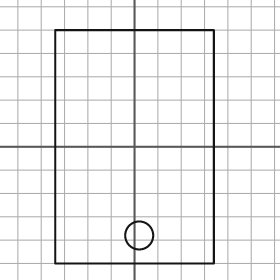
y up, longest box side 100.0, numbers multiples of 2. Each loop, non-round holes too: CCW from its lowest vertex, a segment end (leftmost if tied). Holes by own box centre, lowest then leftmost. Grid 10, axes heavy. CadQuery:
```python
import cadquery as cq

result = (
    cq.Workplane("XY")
    .moveTo(-34.0, -50.0)
    .lineTo(34.0, -50.0)
    .lineTo(34.0, 50.0)
    .lineTo(-34.0, 50.0)
    .close()
    .moveTo(2.0, -38.0)
    .circle(6.0)
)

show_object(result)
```